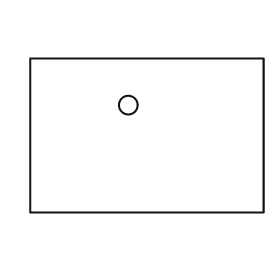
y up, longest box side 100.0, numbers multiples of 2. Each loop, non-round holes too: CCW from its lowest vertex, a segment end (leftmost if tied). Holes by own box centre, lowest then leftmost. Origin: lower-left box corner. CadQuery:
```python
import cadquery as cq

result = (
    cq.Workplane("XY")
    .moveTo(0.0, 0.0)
    .lineTo(100.0, 0.0)
    .lineTo(100.0, 66.0)
    .lineTo(0.0, 66.0)
    .close()
    .moveTo(42.0, 46.0)
    .circle(4.0)
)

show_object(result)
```